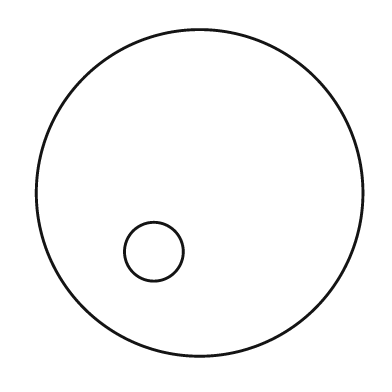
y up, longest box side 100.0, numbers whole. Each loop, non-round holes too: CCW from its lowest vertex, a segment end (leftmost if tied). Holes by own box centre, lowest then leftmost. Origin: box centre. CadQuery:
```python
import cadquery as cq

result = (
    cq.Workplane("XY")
    .moveTo(0.0, 0.0)
    .circle(50.0)
    .moveTo(-14.0, -18.0)
    .circle(9.0)
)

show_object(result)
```